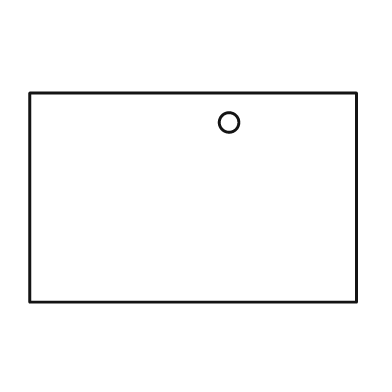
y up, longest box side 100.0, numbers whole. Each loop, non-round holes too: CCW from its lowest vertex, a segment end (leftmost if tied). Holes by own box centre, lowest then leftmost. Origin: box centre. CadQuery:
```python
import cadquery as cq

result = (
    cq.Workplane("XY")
    .moveTo(-50.0, -32.0)
    .lineTo(50.0, -32.0)
    .lineTo(50.0, 32.0)
    .lineTo(-50.0, 32.0)
    .close()
    .moveTo(11.0, 23.0)
    .circle(3.0)
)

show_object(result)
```